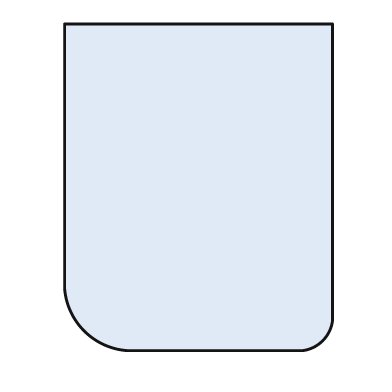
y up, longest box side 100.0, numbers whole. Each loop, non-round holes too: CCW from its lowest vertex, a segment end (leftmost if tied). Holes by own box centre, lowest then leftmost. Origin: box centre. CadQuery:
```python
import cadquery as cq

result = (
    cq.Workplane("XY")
    .moveTo(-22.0, -50.0)
    .lineTo(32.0, -50.0)
    .threePointArc((38.0, -47.0), (41.0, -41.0))
    .lineTo(41.0, 50.0)
    .lineTo(-41.0, 50.0)
    .lineTo(-41.0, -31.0)
    .threePointArc((-35.0, -44.0), (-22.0, -50.0))
    .close()
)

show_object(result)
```